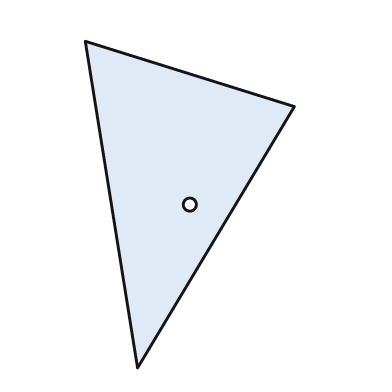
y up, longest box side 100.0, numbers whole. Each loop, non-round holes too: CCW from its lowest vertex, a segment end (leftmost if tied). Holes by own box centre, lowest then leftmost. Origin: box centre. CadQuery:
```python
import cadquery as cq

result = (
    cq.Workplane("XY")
    .moveTo(-16.0, -50.0)
    .lineTo(32.0, 30.0)
    .lineTo(-32.0, 50.0)
    .close()
    .moveTo(0.0, 0.0)
    .circle(2.0)
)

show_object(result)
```